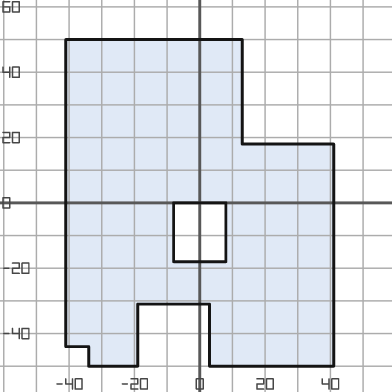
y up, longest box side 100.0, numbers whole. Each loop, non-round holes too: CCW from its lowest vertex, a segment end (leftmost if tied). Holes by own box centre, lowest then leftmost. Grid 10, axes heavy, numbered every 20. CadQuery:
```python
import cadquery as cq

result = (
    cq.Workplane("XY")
    .moveTo(-34.0, -50.0)
    .lineTo(-19.0, -50.0)
    .lineTo(-19.0, -31.0)
    .lineTo(3.0, -31.0)
    .lineTo(3.0, -50.0)
    .lineTo(41.0, -50.0)
    .lineTo(41.0, 18.0)
    .lineTo(13.0, 18.0)
    .lineTo(13.0, 50.0)
    .lineTo(-41.0, 50.0)
    .lineTo(-41.0, -44.0)
    .lineTo(-34.0, -44.0)
    .close()
    .moveTo(-8.0, -18.0)
    .lineTo(8.0, -18.0)
    .lineTo(8.0, 0.0)
    .lineTo(-8.0, 0.0)
    .close()
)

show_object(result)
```